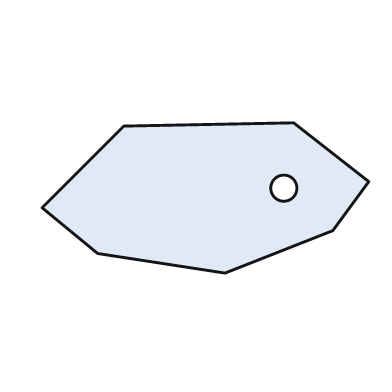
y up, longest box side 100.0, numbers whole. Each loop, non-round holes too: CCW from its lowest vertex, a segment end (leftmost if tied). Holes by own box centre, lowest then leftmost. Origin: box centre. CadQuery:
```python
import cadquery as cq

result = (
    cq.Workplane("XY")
    .moveTo(6.0, -23.0)
    .lineTo(39.0, -10.0)
    .lineTo(50.0, 5.0)
    .lineTo(27.0, 23.0)
    .lineTo(-25.0, 22.0)
    .lineTo(-50.0, -3.0)
    .lineTo(-33.0, -17.0)
    .close()
    .moveTo(24.0, 3.0)
    .circle(4.0)
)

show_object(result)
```